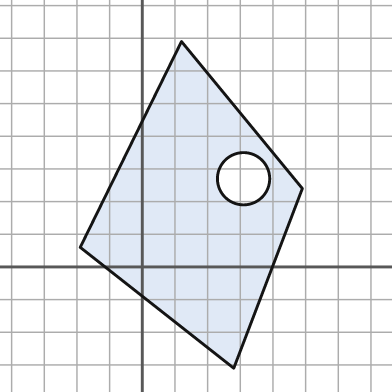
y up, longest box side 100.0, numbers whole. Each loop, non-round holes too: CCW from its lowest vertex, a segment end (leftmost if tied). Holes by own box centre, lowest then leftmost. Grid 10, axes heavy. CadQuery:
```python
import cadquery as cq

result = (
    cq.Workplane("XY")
    .moveTo(28.0, -31.0)
    .lineTo(49.0, 24.0)
    .lineTo(12.0, 69.0)
    .lineTo(-19.0, 6.0)
    .close()
    .moveTo(31.0, 27.0)
    .circle(8.0)
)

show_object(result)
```